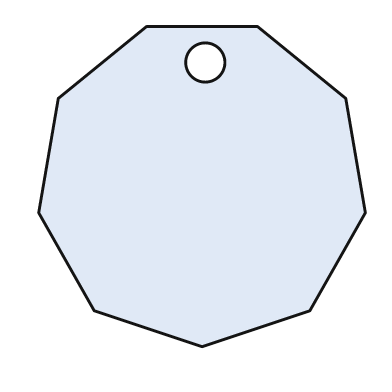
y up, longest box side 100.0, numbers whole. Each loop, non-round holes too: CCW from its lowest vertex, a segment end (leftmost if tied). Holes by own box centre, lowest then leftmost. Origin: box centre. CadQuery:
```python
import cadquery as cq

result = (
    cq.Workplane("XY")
    .moveTo(0.0, -49.0)
    .lineTo(33.0, -38.0)
    .lineTo(50.0, -8.0)
    .lineTo(44.0, 27.0)
    .lineTo(17.0, 49.0)
    .lineTo(-17.0, 49.0)
    .lineTo(-44.0, 27.0)
    .lineTo(-50.0, -8.0)
    .lineTo(-33.0, -38.0)
    .close()
    .moveTo(1.0, 38.0)
    .circle(6.0)
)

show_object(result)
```